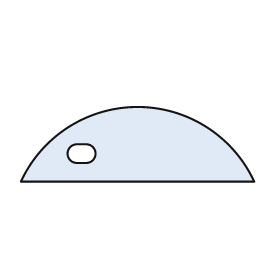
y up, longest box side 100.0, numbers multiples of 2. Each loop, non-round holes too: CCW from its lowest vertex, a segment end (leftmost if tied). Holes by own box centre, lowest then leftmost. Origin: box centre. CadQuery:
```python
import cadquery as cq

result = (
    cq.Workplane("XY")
    .moveTo(-50.0, -16.0)
    .lineTo(50.0, -16.0)
    .threePointArc((0.0, 16.0), (-50.0, -16.0))
    .close()
    .moveTo(-26.0, -8.0)
    .lineTo(-22.0, -8.0)
    .threePointArc((-18.0, -4.0), (-22.0, 0.0))
    .lineTo(-26.0, 0.0)
    .threePointArc((-30.0, -4.0), (-26.0, -8.0))
    .close()
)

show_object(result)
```